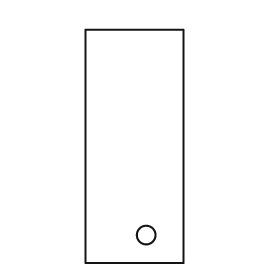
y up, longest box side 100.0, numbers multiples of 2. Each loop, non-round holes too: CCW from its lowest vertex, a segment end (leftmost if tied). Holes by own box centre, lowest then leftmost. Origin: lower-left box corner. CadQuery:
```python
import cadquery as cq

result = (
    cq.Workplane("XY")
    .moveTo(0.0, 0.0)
    .lineTo(42.0, 0.0)
    .lineTo(42.0, 100.0)
    .lineTo(0.0, 100.0)
    .close()
    .moveTo(26.0, 12.0)
    .circle(4.0)
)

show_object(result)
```